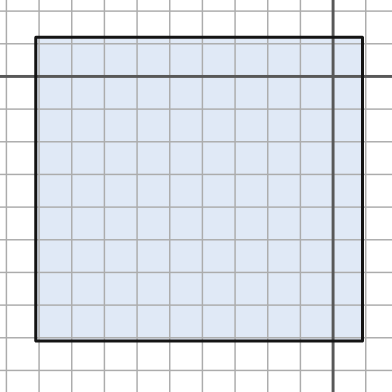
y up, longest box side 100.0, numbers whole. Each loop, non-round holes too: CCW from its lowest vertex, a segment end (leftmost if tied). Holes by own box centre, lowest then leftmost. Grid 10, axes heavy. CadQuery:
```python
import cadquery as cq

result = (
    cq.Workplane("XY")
    .moveTo(-91.0, -81.0)
    .lineTo(9.0, -81.0)
    .lineTo(9.0, 12.0)
    .lineTo(-91.0, 12.0)
    .close()
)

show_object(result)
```